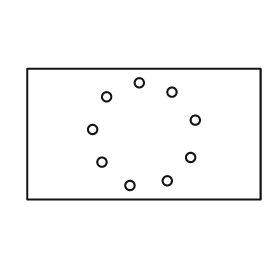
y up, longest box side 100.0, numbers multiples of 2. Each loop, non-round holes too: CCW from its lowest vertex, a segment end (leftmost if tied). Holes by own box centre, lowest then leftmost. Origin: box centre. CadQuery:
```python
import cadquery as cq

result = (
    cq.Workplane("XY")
    .moveTo(-50.0, -28.0)
    .lineTo(50.0, -28.0)
    .lineTo(50.0, 28.0)
    .lineTo(-50.0, 28.0)
    .close()
    .moveTo(-6.0, -22.0)
    .circle(2.0)
    .moveTo(10.0, -20.0)
    .circle(2.0)
    .moveTo(-18.0, -12.0)
    .circle(2.0)
    .moveTo(20.0, -10.0)
    .circle(2.0)
    .moveTo(-22.0, 2.0)
    .circle(2.0)
    .moveTo(22.0, 6.0)
    .circle(2.0)
    .moveTo(-16.0, 16.0)
    .circle(2.0)
    .moveTo(12.0, 18.0)
    .circle(2.0)
    .moveTo(-2.0, 22.0)
    .circle(2.0)
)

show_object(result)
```